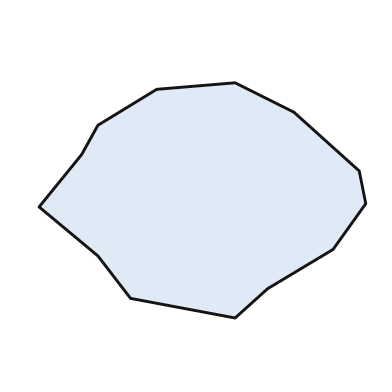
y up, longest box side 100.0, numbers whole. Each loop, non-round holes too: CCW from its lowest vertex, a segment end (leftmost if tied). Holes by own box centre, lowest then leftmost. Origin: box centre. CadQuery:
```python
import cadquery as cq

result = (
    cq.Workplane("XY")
    .moveTo(10.0, -36.0)
    .lineTo(20.0, -27.0)
    .lineTo(40.0, -15.0)
    .lineTo(50.0, -1.0)
    .lineTo(48.0, 9.0)
    .lineTo(28.0, 27.0)
    .lineTo(10.0, 36.0)
    .lineTo(-14.0, 34.0)
    .lineTo(-32.0, 23.0)
    .lineTo(-37.0, 14.0)
    .lineTo(-50.0, -2.0)
    .lineTo(-32.0, -17.0)
    .lineTo(-22.0, -30.0)
    .close()
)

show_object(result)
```